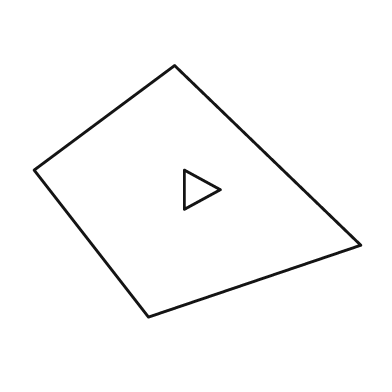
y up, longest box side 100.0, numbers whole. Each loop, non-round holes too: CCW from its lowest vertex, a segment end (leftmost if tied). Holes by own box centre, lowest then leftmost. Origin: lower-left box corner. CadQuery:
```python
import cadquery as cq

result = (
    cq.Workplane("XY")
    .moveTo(35.0, 0.0)
    .lineTo(100.0, 22.0)
    .lineTo(43.0, 77.0)
    .lineTo(0.0, 45.0)
    .close()
    .moveTo(46.0, 33.0)
    .lineTo(57.0, 39.0)
    .lineTo(46.0, 45.0)
    .close()
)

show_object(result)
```